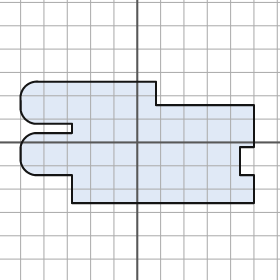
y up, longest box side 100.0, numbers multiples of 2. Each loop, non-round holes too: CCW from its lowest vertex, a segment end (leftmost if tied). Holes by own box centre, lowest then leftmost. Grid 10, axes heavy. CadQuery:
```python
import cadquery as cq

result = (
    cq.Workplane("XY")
    .moveTo(-28.0, -26.0)
    .lineTo(50.0, -26.0)
    .lineTo(50.0, -14.0)
    .lineTo(44.0, -14.0)
    .lineTo(44.0, -2.0)
    .lineTo(50.0, -2.0)
    .lineTo(50.0, 16.0)
    .lineTo(8.0, 16.0)
    .lineTo(8.0, 26.0)
    .lineTo(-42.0, 26.0)
    .threePointArc((-48.0, 24.0), (-50.0, 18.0))
    .lineTo(-50.0, 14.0)
    .threePointArc((-48.0, 10.0), (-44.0, 8.0))
    .lineTo(-28.0, 8.0)
    .lineTo(-28.0, 4.0)
    .lineTo(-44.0, 4.0)
    .threePointArc((-48.0, 2.0), (-50.0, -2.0))
    .lineTo(-50.0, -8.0)
    .threePointArc((-48.0, -12.0), (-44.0, -14.0))
    .lineTo(-28.0, -14.0)
    .close()
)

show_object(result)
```